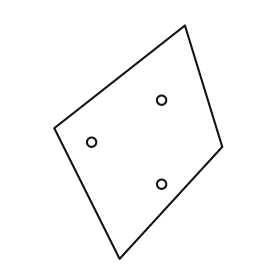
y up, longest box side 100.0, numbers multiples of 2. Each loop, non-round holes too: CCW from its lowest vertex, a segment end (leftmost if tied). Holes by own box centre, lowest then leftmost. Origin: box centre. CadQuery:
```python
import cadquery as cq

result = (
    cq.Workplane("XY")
    .moveTo(-8.0, -50.0)
    .lineTo(36.0, -2.0)
    .lineTo(20.0, 50.0)
    .lineTo(-36.0, 6.0)
    .close()
    .moveTo(10.0, -18.0)
    .circle(2.0)
    .moveTo(-20.0, 0.0)
    .circle(2.0)
    .moveTo(10.0, 18.0)
    .circle(2.0)
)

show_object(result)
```